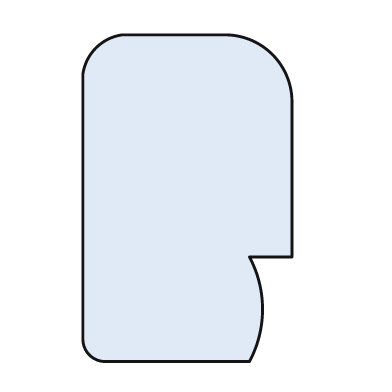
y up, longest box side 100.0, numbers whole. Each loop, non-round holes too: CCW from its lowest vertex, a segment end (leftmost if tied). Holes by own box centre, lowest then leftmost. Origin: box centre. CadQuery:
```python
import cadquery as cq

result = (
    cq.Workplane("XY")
    .moveTo(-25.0, -50.0)
    .lineTo(19.0, -50.0)
    .threePointArc((23.0, -34.0), (19.0, -18.0))
    .lineTo(32.0, -18.0)
    .lineTo(32.0, 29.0)
    .threePointArc((26.0, 44.0), (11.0, 50.0))
    .lineTo(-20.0, 50.0)
    .threePointArc((-28.0, 46.0), (-32.0, 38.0))
    .lineTo(-32.0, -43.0)
    .threePointArc((-30.0, -48.0), (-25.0, -50.0))
    .close()
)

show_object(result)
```